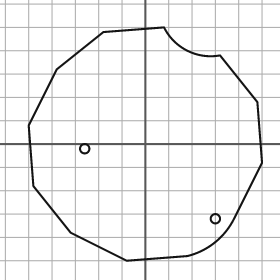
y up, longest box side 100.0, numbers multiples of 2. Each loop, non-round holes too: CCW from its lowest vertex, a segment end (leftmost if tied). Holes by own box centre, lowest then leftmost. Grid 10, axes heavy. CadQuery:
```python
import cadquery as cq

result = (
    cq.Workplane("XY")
    .moveTo(-8.0, -50.0)
    .lineTo(18.0, -48.0)
    .threePointArc((30.0, -42.0), (38.0, -32.0))
    .lineTo(50.0, -8.0)
    .lineTo(48.0, 18.0)
    .lineTo(32.0, 38.0)
    .threePointArc((18.0, 40.0), (8.0, 50.0))
    .lineTo(-18.0, 48.0)
    .lineTo(-38.0, 32.0)
    .lineTo(-50.0, 8.0)
    .lineTo(-48.0, -18.0)
    .lineTo(-32.0, -38.0)
    .close()
    .moveTo(30.0, -32.0)
    .circle(2.0)
    .moveTo(-26.0, -2.0)
    .circle(2.0)
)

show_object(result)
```